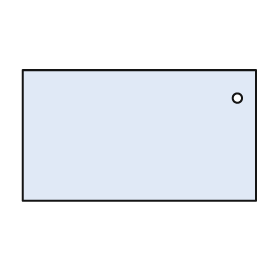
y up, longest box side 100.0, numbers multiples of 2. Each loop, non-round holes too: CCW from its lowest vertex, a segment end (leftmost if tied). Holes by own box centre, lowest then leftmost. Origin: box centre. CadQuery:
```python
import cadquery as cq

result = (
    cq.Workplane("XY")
    .moveTo(-50.0, -28.0)
    .lineTo(50.0, -28.0)
    .lineTo(50.0, 28.0)
    .lineTo(-50.0, 28.0)
    .close()
    .moveTo(42.0, 16.0)
    .circle(2.0)
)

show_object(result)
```